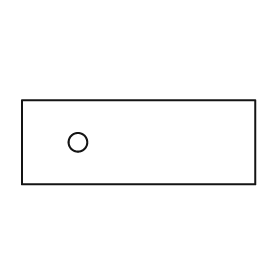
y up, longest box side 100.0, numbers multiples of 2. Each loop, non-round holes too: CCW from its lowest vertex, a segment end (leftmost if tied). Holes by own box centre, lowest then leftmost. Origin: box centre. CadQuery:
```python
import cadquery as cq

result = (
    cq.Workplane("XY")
    .moveTo(-50.0, -18.0)
    .lineTo(50.0, -18.0)
    .lineTo(50.0, 18.0)
    .lineTo(-50.0, 18.0)
    .close()
    .moveTo(-26.0, 0.0)
    .circle(4.0)
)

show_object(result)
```